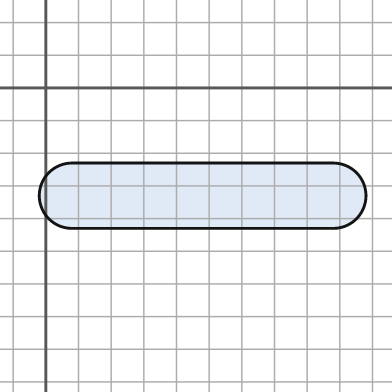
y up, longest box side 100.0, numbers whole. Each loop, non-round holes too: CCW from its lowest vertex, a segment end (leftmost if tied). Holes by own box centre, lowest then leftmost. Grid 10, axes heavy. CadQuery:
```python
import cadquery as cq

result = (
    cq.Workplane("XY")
    .moveTo(8.0, -43.0)
    .lineTo(88.0, -43.0)
    .threePointArc((98.0, -33.0), (88.0, -23.0))
    .lineTo(8.0, -23.0)
    .threePointArc((-2.0, -33.0), (8.0, -43.0))
    .close()
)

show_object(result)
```